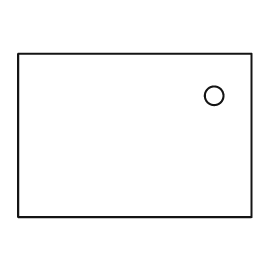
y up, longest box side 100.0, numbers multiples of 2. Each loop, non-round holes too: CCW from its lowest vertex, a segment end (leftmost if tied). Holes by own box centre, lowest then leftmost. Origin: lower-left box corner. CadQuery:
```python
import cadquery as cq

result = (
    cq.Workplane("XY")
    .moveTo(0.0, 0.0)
    .lineTo(100.0, 0.0)
    .lineTo(100.0, 70.0)
    .lineTo(0.0, 70.0)
    .close()
    .moveTo(84.0, 52.0)
    .circle(4.0)
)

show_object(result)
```